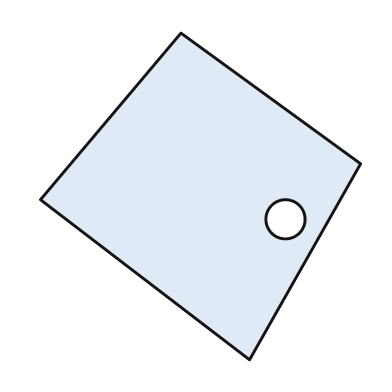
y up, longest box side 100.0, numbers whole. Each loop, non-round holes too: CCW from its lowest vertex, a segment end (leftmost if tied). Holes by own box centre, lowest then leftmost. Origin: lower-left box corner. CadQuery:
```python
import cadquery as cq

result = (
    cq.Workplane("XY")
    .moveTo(64.0, 0.0)
    .lineTo(98.0, 60.0)
    .lineTo(43.0, 100.0)
    .lineTo(0.0, 49.0)
    .close()
    .moveTo(75.0, 43.0)
    .circle(6.0)
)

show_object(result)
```